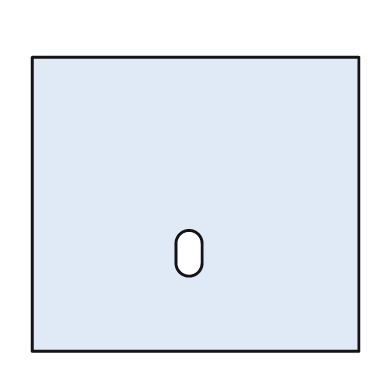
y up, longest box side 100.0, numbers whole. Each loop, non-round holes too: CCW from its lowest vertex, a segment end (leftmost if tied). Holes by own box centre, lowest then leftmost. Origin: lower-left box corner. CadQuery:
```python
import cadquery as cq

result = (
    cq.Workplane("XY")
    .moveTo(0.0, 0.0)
    .lineTo(100.0, 0.0)
    .lineTo(100.0, 90.0)
    .lineTo(0.0, 90.0)
    .close()
    .moveTo(44.0, 27.0)
    .threePointArc((48.0, 23.0), (52.0, 27.0))
    .lineTo(52.0, 33.0)
    .threePointArc((48.0, 37.0), (44.0, 33.0))
    .close()
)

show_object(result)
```